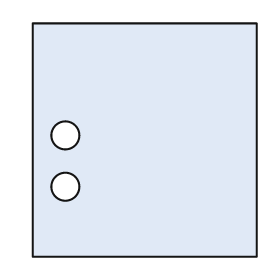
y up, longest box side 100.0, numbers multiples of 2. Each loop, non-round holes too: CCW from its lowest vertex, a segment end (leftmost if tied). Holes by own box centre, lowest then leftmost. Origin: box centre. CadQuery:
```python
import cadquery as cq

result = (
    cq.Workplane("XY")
    .moveTo(-48.0, -50.0)
    .lineTo(48.0, -50.0)
    .lineTo(48.0, 50.0)
    .lineTo(-48.0, 50.0)
    .close()
    .moveTo(-34.0, -20.0)
    .circle(6.0)
    .moveTo(-34.0, 2.0)
    .circle(6.0)
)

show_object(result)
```